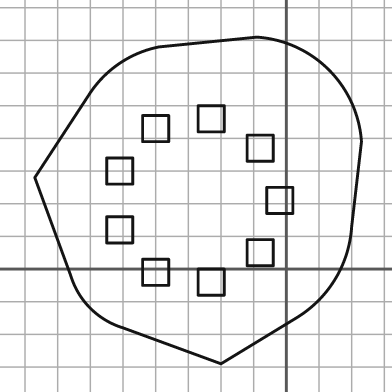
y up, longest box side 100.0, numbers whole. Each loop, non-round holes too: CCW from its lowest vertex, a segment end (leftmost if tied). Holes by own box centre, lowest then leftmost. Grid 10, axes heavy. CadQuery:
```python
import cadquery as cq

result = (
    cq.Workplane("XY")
    .moveTo(-20.0, -29.0)
    .lineTo(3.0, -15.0)
    .threePointArc((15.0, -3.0), (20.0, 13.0))
    .lineTo(23.0, 39.0)
    .threePointArc((13.0, 61.0), (-9.0, 71.0))
    .lineTo(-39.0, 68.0)
    .threePointArc((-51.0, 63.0), (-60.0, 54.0))
    .lineTo(-77.0, 28.0)
    .lineTo(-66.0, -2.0)
    .threePointArc((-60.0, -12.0), (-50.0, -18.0))
    .close()
    .moveTo(-27.0, -8.0)
    .lineTo(-19.0, -8.0)
    .lineTo(-19.0, 0.0)
    .lineTo(-27.0, 0.0)
    .close()
    .moveTo(-44.0, -5.0)
    .lineTo(-36.0, -5.0)
    .lineTo(-36.0, 3.0)
    .lineTo(-44.0, 3.0)
    .close()
    .moveTo(-12.0, 1.0)
    .lineTo(-4.0, 1.0)
    .lineTo(-4.0, 9.0)
    .lineTo(-12.0, 9.0)
    .close()
    .moveTo(-55.0, 8.0)
    .lineTo(-47.0, 8.0)
    .lineTo(-47.0, 16.0)
    .lineTo(-55.0, 16.0)
    .close()
    .moveTo(-6.0, 17.0)
    .lineTo(2.0, 17.0)
    .lineTo(2.0, 25.0)
    .lineTo(-6.0, 25.0)
    .close()
    .moveTo(-55.0, 26.0)
    .lineTo(-47.0, 26.0)
    .lineTo(-47.0, 34.0)
    .lineTo(-55.0, 34.0)
    .close()
    .moveTo(-12.0, 33.0)
    .lineTo(-4.0, 33.0)
    .lineTo(-4.0, 41.0)
    .lineTo(-12.0, 41.0)
    .close()
    .moveTo(-44.0, 39.0)
    .lineTo(-36.0, 39.0)
    .lineTo(-36.0, 47.0)
    .lineTo(-44.0, 47.0)
    .close()
    .moveTo(-27.0, 42.0)
    .lineTo(-19.0, 42.0)
    .lineTo(-19.0, 50.0)
    .lineTo(-27.0, 50.0)
    .close()
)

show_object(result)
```